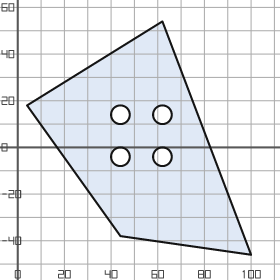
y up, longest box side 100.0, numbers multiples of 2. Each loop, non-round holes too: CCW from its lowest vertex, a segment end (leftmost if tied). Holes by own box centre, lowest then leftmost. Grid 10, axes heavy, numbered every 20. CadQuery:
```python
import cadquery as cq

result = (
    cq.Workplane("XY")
    .moveTo(100.0, -46.0)
    .lineTo(62.0, 54.0)
    .lineTo(4.0, 18.0)
    .lineTo(44.0, -38.0)
    .close()
    .moveTo(44.0, -4.0)
    .circle(4.0)
    .moveTo(62.0, -4.0)
    .circle(4.0)
    .moveTo(44.0, 14.0)
    .circle(4.0)
    .moveTo(62.0, 14.0)
    .circle(4.0)
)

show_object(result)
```